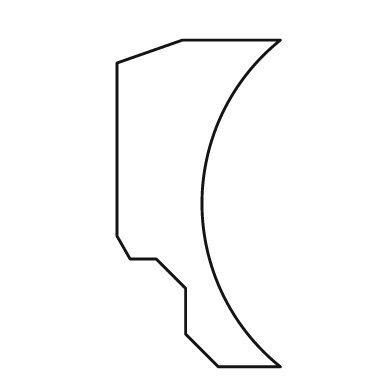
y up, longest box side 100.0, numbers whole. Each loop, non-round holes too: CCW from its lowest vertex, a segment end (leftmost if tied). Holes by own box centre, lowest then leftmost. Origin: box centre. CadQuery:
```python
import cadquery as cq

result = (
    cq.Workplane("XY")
    .moveTo(6.0, -50.0)
    .lineTo(25.0, -50.0)
    .threePointArc((1.0, 0.0), (25.0, 50.0))
    .lineTo(-5.0, 50.0)
    .lineTo(-25.0, 43.0)
    .lineTo(-25.0, -10.0)
    .lineTo(-21.0, -17.0)
    .lineTo(-13.0, -17.0)
    .lineTo(-4.0, -26.0)
    .lineTo(-4.0, -40.0)
    .close()
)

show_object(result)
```